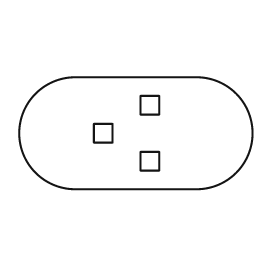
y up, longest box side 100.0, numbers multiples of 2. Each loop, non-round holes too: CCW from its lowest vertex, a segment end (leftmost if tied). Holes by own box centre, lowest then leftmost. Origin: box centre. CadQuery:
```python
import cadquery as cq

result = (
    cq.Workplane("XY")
    .moveTo(-26.0, -24.0)
    .lineTo(26.0, -24.0)
    .threePointArc((50.0, 0.0), (26.0, 24.0))
    .lineTo(-26.0, 24.0)
    .threePointArc((-50.0, 0.0), (-26.0, -24.0))
    .close()
    .moveTo(2.0, -16.0)
    .lineTo(10.0, -16.0)
    .lineTo(10.0, -8.0)
    .lineTo(2.0, -8.0)
    .close()
    .moveTo(-18.0, -4.0)
    .lineTo(-10.0, -4.0)
    .lineTo(-10.0, 4.0)
    .lineTo(-18.0, 4.0)
    .close()
    .moveTo(2.0, 8.0)
    .lineTo(10.0, 8.0)
    .lineTo(10.0, 16.0)
    .lineTo(2.0, 16.0)
    .close()
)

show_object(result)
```